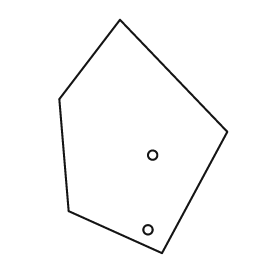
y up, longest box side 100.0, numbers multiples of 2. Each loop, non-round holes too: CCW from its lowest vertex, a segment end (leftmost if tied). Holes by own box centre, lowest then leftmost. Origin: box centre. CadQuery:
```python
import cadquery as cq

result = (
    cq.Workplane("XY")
    .moveTo(8.0, -50.0)
    .lineTo(36.0, 2.0)
    .lineTo(-10.0, 50.0)
    .lineTo(-36.0, 16.0)
    .lineTo(-32.0, -32.0)
    .close()
    .moveTo(2.0, -40.0)
    .circle(2.0)
    .moveTo(4.0, -8.0)
    .circle(2.0)
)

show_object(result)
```